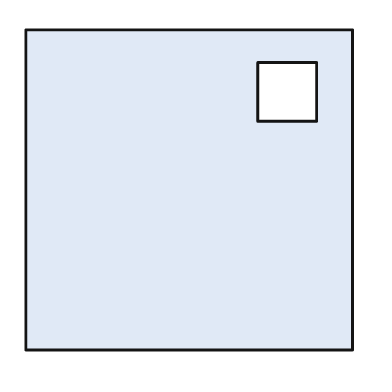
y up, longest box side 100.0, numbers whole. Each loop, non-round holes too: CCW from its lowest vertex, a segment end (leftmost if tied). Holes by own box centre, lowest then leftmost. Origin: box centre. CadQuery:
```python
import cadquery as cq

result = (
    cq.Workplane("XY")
    .moveTo(-50.0, -49.0)
    .lineTo(50.0, -49.0)
    .lineTo(50.0, 49.0)
    .lineTo(-50.0, 49.0)
    .close()
    .moveTo(21.0, 21.0)
    .lineTo(39.0, 21.0)
    .lineTo(39.0, 39.0)
    .lineTo(21.0, 39.0)
    .close()
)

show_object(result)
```